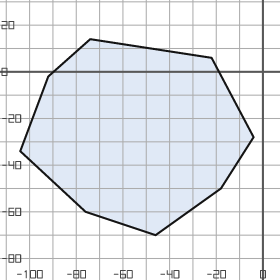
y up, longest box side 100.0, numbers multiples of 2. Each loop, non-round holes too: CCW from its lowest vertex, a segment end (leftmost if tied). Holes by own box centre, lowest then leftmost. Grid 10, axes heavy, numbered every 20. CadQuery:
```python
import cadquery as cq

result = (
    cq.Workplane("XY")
    .moveTo(-46.0, -70.0)
    .lineTo(-18.0, -50.0)
    .lineTo(-4.0, -28.0)
    .lineTo(-22.0, 6.0)
    .lineTo(-74.0, 14.0)
    .lineTo(-92.0, -2.0)
    .lineTo(-104.0, -34.0)
    .lineTo(-76.0, -60.0)
    .close()
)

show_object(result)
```